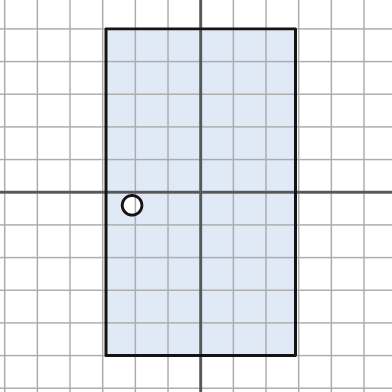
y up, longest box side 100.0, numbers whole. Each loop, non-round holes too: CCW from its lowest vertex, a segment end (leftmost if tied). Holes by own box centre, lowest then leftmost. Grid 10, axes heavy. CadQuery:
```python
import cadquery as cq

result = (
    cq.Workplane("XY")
    .moveTo(-29.0, -50.0)
    .lineTo(29.0, -50.0)
    .lineTo(29.0, 50.0)
    .lineTo(-29.0, 50.0)
    .close()
    .moveTo(-21.0, -4.0)
    .circle(3.0)
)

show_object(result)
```